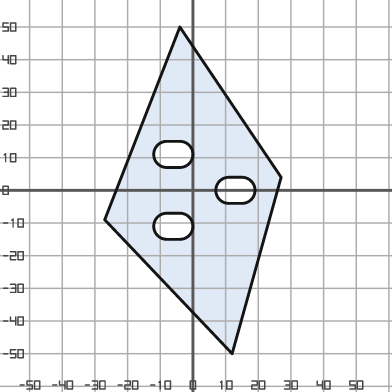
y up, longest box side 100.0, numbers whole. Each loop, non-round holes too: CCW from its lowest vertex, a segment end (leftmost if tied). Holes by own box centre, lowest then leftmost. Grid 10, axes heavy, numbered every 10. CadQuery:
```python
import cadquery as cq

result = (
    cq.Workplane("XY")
    .moveTo(12.0, -50.0)
    .lineTo(27.0, 4.0)
    .lineTo(-4.0, 50.0)
    .lineTo(-27.0, -9.0)
    .close()
    .moveTo(-8.0, -15.0)
    .lineTo(-4.0, -15.0)
    .threePointArc((0.0, -11.0), (-4.0, -7.0))
    .lineTo(-8.0, -7.0)
    .threePointArc((-12.0, -11.0), (-8.0, -15.0))
    .close()
    .moveTo(11.0, -4.0)
    .lineTo(15.0, -4.0)
    .threePointArc((19.0, 0.0), (15.0, 4.0))
    .lineTo(11.0, 4.0)
    .threePointArc((7.0, 0.0), (11.0, -4.0))
    .close()
    .moveTo(-8.0, 7.0)
    .lineTo(-4.0, 7.0)
    .threePointArc((0.0, 11.0), (-4.0, 15.0))
    .lineTo(-8.0, 15.0)
    .threePointArc((-12.0, 11.0), (-8.0, 7.0))
    .close()
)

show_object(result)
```